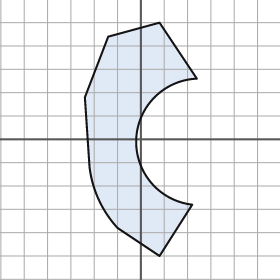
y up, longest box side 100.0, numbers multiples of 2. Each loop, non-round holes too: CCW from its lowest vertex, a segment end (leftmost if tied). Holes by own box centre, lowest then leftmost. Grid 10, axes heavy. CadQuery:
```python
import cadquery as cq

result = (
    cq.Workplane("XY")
    .moveTo(8.0, -50.0)
    .lineTo(22.0, -28.0)
    .threePointArc((-2.0, 0.0), (24.0, 26.0))
    .lineTo(8.0, 50.0)
    .lineTo(-14.0, 44.0)
    .lineTo(-24.0, 18.0)
    .lineTo(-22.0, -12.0)
    .threePointArc((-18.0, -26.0), (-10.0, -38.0))
    .close()
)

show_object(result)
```